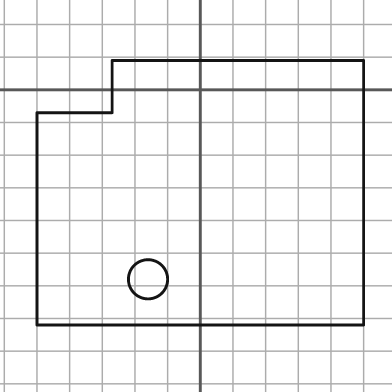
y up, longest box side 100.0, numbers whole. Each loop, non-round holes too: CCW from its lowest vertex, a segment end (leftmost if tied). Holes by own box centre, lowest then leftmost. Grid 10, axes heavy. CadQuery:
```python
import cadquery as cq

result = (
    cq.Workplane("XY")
    .moveTo(-50.0, -72.0)
    .lineTo(50.0, -72.0)
    .lineTo(50.0, 9.0)
    .lineTo(-27.0, 9.0)
    .lineTo(-27.0, -7.0)
    .lineTo(-50.0, -7.0)
    .close()
    .moveTo(-16.0, -58.0)
    .circle(6.0)
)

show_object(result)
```